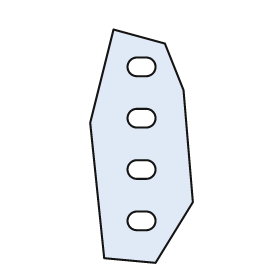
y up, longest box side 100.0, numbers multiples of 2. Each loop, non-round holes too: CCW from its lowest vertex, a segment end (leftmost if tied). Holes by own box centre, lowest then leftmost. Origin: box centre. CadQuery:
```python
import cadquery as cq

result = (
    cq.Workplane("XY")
    .moveTo(6.0, -50.0)
    .lineTo(22.0, -24.0)
    .lineTo(18.0, 24.0)
    .lineTo(10.0, 44.0)
    .lineTo(-12.0, 50.0)
    .lineTo(-22.0, 10.0)
    .lineTo(-16.0, -48.0)
    .close()
    .moveTo(-2.0, -36.0)
    .lineTo(2.0, -36.0)
    .threePointArc((6.0, -32.0), (2.0, -28.0))
    .lineTo(-2.0, -28.0)
    .threePointArc((-6.0, -32.0), (-2.0, -36.0))
    .close()
    .moveTo(-2.0, -14.0)
    .lineTo(2.0, -14.0)
    .threePointArc((6.0, -10.0), (2.0, -6.0))
    .lineTo(-2.0, -6.0)
    .threePointArc((-6.0, -10.0), (-2.0, -14.0))
    .close()
    .moveTo(-2.0, 8.0)
    .lineTo(2.0, 8.0)
    .threePointArc((6.0, 12.0), (2.0, 16.0))
    .lineTo(-2.0, 16.0)
    .threePointArc((-6.0, 12.0), (-2.0, 8.0))
    .close()
    .moveTo(-2.0, 30.0)
    .lineTo(2.0, 30.0)
    .threePointArc((6.0, 34.0), (2.0, 38.0))
    .lineTo(-2.0, 38.0)
    .threePointArc((-6.0, 34.0), (-2.0, 30.0))
    .close()
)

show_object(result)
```